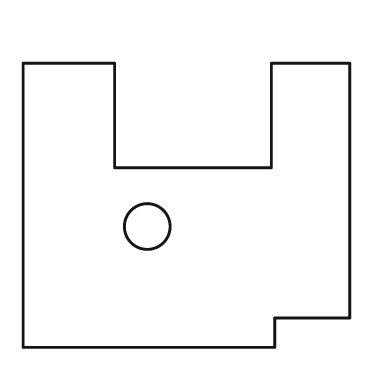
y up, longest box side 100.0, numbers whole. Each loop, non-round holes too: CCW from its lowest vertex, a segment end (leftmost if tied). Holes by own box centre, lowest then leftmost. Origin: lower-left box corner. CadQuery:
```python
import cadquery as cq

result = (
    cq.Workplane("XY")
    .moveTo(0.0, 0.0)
    .lineTo(77.0, 0.0)
    .lineTo(77.0, 9.0)
    .lineTo(100.0, 9.0)
    .lineTo(100.0, 87.0)
    .lineTo(76.0, 87.0)
    .lineTo(76.0, 55.0)
    .lineTo(28.0, 55.0)
    .lineTo(28.0, 87.0)
    .lineTo(0.0, 87.0)
    .close()
    .moveTo(38.0, 37.0)
    .circle(7.0)
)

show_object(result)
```